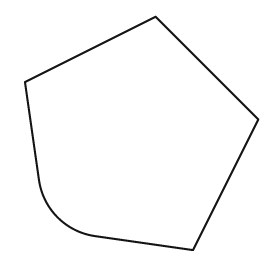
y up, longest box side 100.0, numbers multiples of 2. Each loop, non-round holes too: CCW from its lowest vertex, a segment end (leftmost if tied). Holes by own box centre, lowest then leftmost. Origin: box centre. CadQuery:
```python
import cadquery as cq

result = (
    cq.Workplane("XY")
    .moveTo(22.0, -50.0)
    .lineTo(50.0, 6.0)
    .lineTo(6.0, 50.0)
    .lineTo(-50.0, 22.0)
    .lineTo(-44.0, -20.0)
    .threePointArc((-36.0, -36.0), (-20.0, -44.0))
    .close()
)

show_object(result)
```